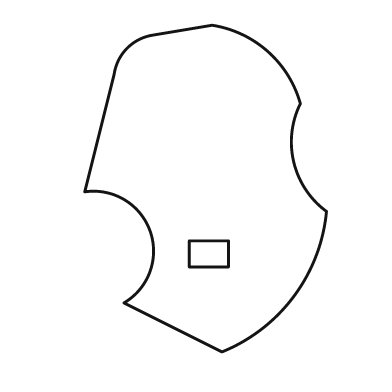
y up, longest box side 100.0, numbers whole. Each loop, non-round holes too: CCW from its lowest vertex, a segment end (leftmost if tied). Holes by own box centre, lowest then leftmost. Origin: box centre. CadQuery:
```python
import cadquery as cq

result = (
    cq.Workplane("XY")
    .moveTo(5.0, -50.0)
    .threePointArc((27.0, -33.0), (37.0, -7.0))
    .threePointArc((27.0, 8.0), (29.0, 26.0))
    .threePointArc((19.0, 42.0), (2.0, 50.0))
    .lineTo(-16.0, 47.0)
    .threePointArc((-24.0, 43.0), (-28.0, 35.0))
    .lineTo(-37.0, -1.0)
    .threePointArc((-17.0, -13.0), (-25.0, -35.0))
    .close()
    .moveTo(-5.0, -24.0)
    .lineTo(7.0, -24.0)
    .lineTo(7.0, -16.0)
    .lineTo(-5.0, -16.0)
    .close()
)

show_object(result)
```